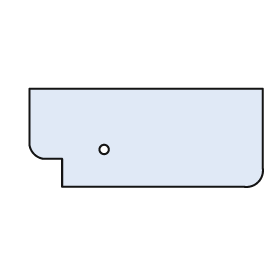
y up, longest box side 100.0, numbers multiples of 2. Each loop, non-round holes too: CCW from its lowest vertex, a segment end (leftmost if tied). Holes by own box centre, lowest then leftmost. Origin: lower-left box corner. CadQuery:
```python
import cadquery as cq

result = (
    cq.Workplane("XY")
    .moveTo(14.0, 0.0)
    .lineTo(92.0, 0.0)
    .threePointArc((98.0, 2.0), (100.0, 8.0))
    .lineTo(100.0, 42.0)
    .lineTo(0.0, 42.0)
    .lineTo(0.0, 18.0)
    .threePointArc((2.0, 14.0), (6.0, 12.0))
    .lineTo(14.0, 12.0)
    .close()
    .moveTo(32.0, 16.0)
    .circle(2.0)
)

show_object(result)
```